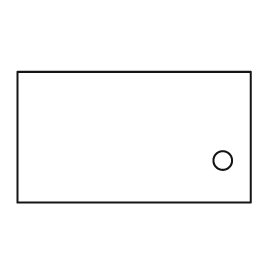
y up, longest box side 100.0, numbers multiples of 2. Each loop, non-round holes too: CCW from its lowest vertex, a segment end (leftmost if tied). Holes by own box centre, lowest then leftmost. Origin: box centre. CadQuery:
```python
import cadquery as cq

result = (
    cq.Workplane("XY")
    .moveTo(-50.0, -28.0)
    .lineTo(50.0, -28.0)
    .lineTo(50.0, 28.0)
    .lineTo(-50.0, 28.0)
    .close()
    .moveTo(38.0, -10.0)
    .circle(4.0)
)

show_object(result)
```